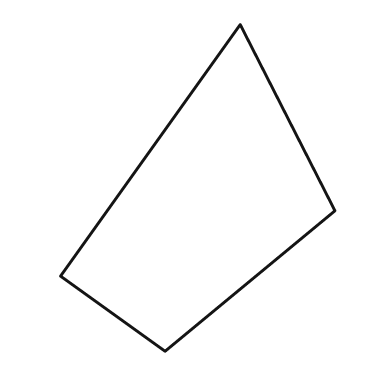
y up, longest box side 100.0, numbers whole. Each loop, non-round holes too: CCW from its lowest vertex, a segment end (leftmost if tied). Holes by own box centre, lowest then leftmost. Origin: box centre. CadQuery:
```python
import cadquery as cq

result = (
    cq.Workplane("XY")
    .moveTo(-10.0, -50.0)
    .lineTo(42.0, -7.0)
    .lineTo(13.0, 50.0)
    .lineTo(-42.0, -27.0)
    .close()
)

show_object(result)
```